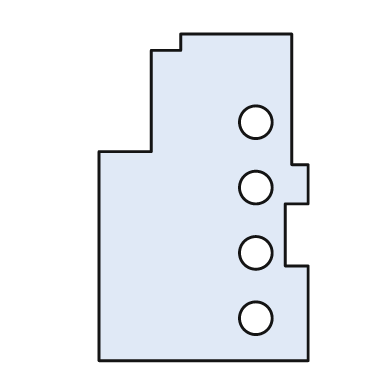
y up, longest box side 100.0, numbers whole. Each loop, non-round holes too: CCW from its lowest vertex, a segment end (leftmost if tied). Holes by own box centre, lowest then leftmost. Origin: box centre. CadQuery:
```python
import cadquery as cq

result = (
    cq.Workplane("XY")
    .moveTo(-32.0, -50.0)
    .lineTo(32.0, -50.0)
    .lineTo(32.0, -21.0)
    .lineTo(25.0, -21.0)
    .lineTo(25.0, -2.0)
    .lineTo(32.0, -2.0)
    .lineTo(32.0, 10.0)
    .lineTo(27.0, 10.0)
    .lineTo(27.0, 50.0)
    .lineTo(-7.0, 50.0)
    .lineTo(-7.0, 45.0)
    .lineTo(-16.0, 45.0)
    .lineTo(-16.0, 14.0)
    .lineTo(-32.0, 14.0)
    .close()
    .moveTo(16.0, -37.0)
    .circle(5.0)
    .moveTo(16.0, -17.0)
    .circle(5.0)
    .moveTo(16.0, 3.0)
    .circle(5.0)
    .moveTo(16.0, 23.0)
    .circle(5.0)
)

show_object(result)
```